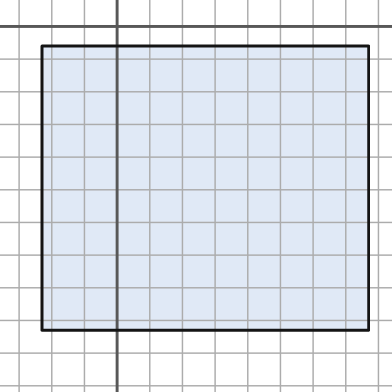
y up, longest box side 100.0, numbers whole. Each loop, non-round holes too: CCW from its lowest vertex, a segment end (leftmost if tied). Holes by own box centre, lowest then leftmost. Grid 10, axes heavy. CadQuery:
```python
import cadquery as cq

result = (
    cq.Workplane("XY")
    .moveTo(-23.0, -93.0)
    .lineTo(77.0, -93.0)
    .lineTo(77.0, -6.0)
    .lineTo(-23.0, -6.0)
    .close()
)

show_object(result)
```